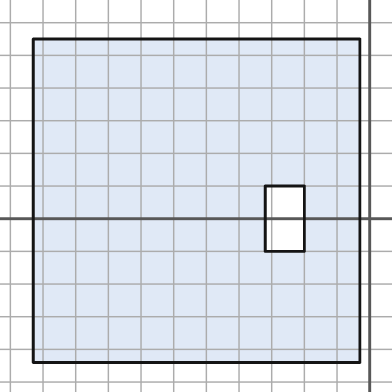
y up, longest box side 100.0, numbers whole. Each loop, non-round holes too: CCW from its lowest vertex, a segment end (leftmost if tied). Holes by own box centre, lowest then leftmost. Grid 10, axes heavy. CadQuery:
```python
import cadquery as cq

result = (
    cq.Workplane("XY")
    .moveTo(-103.0, -44.0)
    .lineTo(-3.0, -44.0)
    .lineTo(-3.0, 55.0)
    .lineTo(-103.0, 55.0)
    .close()
    .moveTo(-32.0, -10.0)
    .lineTo(-20.0, -10.0)
    .lineTo(-20.0, 10.0)
    .lineTo(-32.0, 10.0)
    .close()
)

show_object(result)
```